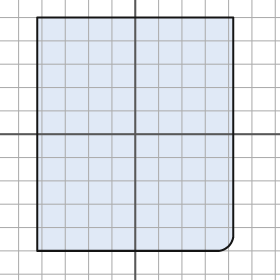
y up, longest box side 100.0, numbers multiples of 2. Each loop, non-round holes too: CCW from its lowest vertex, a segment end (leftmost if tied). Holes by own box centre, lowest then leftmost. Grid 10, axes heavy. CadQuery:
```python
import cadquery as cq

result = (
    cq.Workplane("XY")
    .moveTo(-42.0, -50.0)
    .lineTo(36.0, -50.0)
    .threePointArc((40.0, -48.0), (42.0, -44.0))
    .lineTo(42.0, 50.0)
    .lineTo(-42.0, 50.0)
    .close()
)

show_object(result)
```